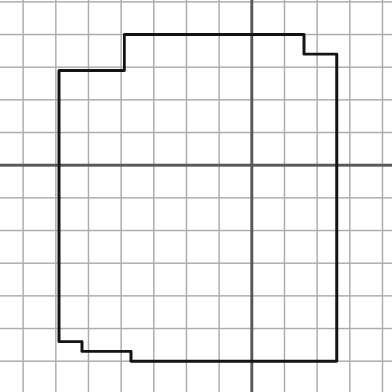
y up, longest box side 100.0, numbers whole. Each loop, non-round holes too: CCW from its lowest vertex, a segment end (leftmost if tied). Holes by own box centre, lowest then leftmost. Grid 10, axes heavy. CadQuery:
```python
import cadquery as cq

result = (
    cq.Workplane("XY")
    .moveTo(-37.0, -60.0)
    .lineTo(26.0, -60.0)
    .lineTo(26.0, 34.0)
    .lineTo(16.0, 34.0)
    .lineTo(16.0, 40.0)
    .lineTo(-39.0, 40.0)
    .lineTo(-39.0, 29.0)
    .lineTo(-59.0, 29.0)
    .lineTo(-59.0, -54.0)
    .lineTo(-52.0, -54.0)
    .lineTo(-52.0, -57.0)
    .lineTo(-37.0, -57.0)
    .close()
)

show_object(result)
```